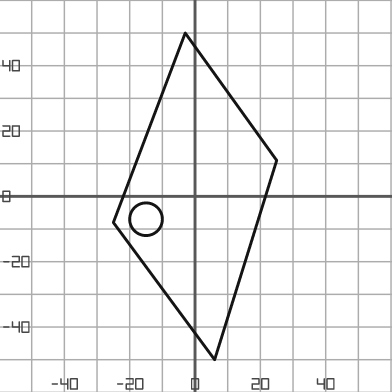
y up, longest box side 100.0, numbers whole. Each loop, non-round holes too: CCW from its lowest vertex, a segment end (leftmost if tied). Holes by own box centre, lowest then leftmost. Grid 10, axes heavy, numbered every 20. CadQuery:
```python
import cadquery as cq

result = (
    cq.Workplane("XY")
    .moveTo(6.0, -50.0)
    .lineTo(25.0, 11.0)
    .lineTo(-3.0, 50.0)
    .lineTo(-25.0, -8.0)
    .close()
    .moveTo(-15.0, -7.0)
    .circle(5.0)
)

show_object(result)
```